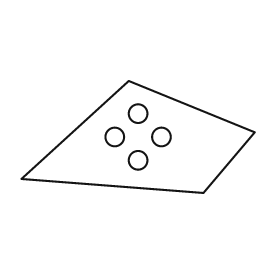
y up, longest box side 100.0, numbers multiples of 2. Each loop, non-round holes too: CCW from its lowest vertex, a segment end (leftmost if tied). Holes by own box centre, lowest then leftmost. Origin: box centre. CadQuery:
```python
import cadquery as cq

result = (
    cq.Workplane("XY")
    .moveTo(28.0, -24.0)
    .lineTo(50.0, 2.0)
    .lineTo(-4.0, 24.0)
    .lineTo(-50.0, -18.0)
    .close()
    .moveTo(0.0, -10.0)
    .circle(4.0)
    .moveTo(-10.0, 0.0)
    .circle(4.0)
    .moveTo(10.0, 0.0)
    .circle(4.0)
    .moveTo(0.0, 10.0)
    .circle(4.0)
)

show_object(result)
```